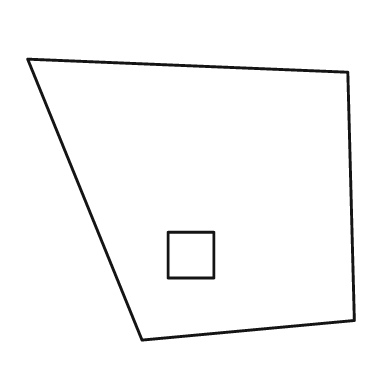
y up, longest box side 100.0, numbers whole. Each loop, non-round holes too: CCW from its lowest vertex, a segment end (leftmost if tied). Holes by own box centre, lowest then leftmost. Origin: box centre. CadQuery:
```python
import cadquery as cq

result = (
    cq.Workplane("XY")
    .moveTo(-15.0, -43.0)
    .lineTo(50.0, -37.0)
    .lineTo(48.0, 39.0)
    .lineTo(-50.0, 43.0)
    .close()
    .moveTo(-7.0, -24.0)
    .lineTo(7.0, -24.0)
    .lineTo(7.0, -10.0)
    .lineTo(-7.0, -10.0)
    .close()
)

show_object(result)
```